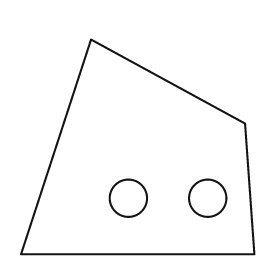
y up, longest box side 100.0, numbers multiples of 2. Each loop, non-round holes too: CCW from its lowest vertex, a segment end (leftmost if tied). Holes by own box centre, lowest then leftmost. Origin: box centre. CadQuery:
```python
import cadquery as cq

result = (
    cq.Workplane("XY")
    .moveTo(-50.0, -46.0)
    .lineTo(50.0, -46.0)
    .lineTo(46.0, 10.0)
    .lineTo(-20.0, 46.0)
    .close()
    .moveTo(-4.0, -22.0)
    .circle(8.0)
    .moveTo(30.0, -22.0)
    .circle(8.0)
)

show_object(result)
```